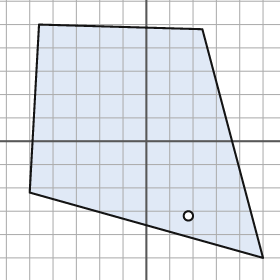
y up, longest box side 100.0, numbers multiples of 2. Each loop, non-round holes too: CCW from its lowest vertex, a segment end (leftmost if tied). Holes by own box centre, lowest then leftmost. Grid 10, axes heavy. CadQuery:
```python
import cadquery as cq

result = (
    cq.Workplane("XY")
    .moveTo(50.0, -50.0)
    .lineTo(24.0, 48.0)
    .lineTo(-46.0, 50.0)
    .lineTo(-50.0, -22.0)
    .close()
    .moveTo(18.0, -32.0)
    .circle(2.0)
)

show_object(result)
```